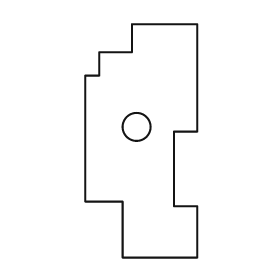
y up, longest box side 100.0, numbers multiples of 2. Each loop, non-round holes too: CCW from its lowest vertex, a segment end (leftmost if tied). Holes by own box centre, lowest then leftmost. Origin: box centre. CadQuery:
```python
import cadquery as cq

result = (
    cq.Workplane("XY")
    .moveTo(-8.0, -50.0)
    .lineTo(24.0, -50.0)
    .lineTo(24.0, -28.0)
    .lineTo(14.0, -28.0)
    .lineTo(14.0, 4.0)
    .lineTo(24.0, 4.0)
    .lineTo(24.0, 50.0)
    .lineTo(-4.0, 50.0)
    .lineTo(-4.0, 38.0)
    .lineTo(-18.0, 38.0)
    .lineTo(-18.0, 28.0)
    .lineTo(-24.0, 28.0)
    .lineTo(-24.0, -26.0)
    .lineTo(-8.0, -26.0)
    .close()
    .moveTo(-2.0, 6.0)
    .circle(6.0)
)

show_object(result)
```